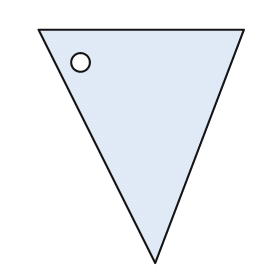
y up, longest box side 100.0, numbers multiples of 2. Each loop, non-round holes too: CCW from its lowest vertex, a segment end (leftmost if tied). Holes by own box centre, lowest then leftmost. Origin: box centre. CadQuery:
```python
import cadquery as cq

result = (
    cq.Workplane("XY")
    .moveTo(6.0, -50.0)
    .lineTo(44.0, 50.0)
    .lineTo(-44.0, 50.0)
    .close()
    .moveTo(-26.0, 36.0)
    .circle(4.0)
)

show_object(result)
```